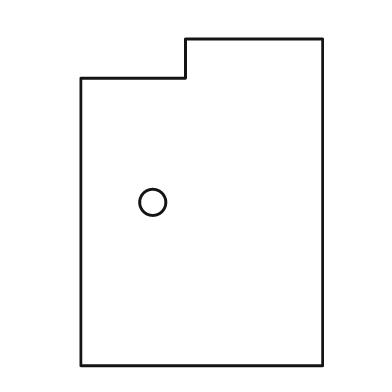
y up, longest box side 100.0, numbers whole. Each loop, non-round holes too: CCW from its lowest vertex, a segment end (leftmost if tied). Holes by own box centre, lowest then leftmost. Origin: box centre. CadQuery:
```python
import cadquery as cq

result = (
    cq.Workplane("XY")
    .moveTo(-37.0, -50.0)
    .lineTo(37.0, -50.0)
    .lineTo(37.0, 50.0)
    .lineTo(-5.0, 50.0)
    .lineTo(-5.0, 38.0)
    .lineTo(-37.0, 38.0)
    .close()
    .moveTo(-15.0, 0.0)
    .circle(4.0)
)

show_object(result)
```